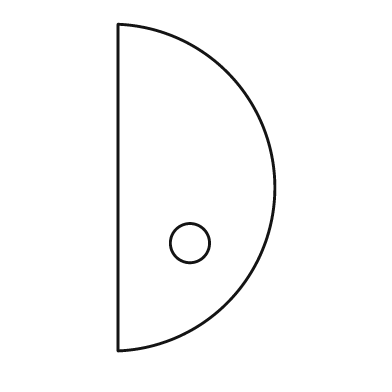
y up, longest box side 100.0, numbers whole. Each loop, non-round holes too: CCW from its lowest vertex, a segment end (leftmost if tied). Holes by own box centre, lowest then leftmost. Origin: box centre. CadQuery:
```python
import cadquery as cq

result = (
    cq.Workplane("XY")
    .moveTo(-24.0, -50.0)
    .threePointArc((24.0, 0.0), (-24.0, 50.0))
    .close()
    .moveTo(-2.0, -17.0)
    .circle(6.0)
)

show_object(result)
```